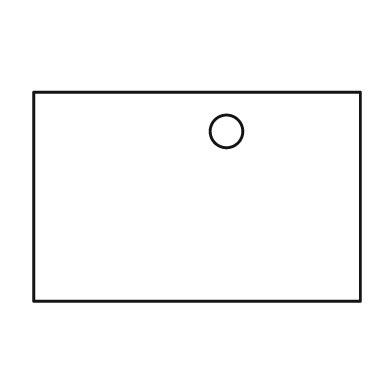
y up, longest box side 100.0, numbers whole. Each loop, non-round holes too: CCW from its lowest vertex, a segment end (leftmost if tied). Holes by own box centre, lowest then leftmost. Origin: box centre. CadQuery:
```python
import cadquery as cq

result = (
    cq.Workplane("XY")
    .moveTo(-50.0, -32.0)
    .lineTo(50.0, -32.0)
    .lineTo(50.0, 32.0)
    .lineTo(-50.0, 32.0)
    .close()
    .moveTo(9.0, 20.0)
    .circle(5.0)
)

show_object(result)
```